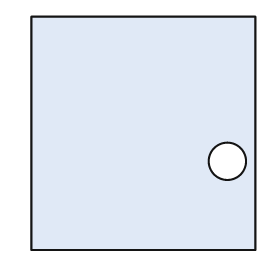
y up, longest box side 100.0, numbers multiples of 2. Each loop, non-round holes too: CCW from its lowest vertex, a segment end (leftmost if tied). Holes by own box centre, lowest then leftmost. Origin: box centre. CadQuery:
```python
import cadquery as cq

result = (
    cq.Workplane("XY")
    .moveTo(-48.0, -50.0)
    .lineTo(48.0, -50.0)
    .lineTo(48.0, 50.0)
    .lineTo(-48.0, 50.0)
    .close()
    .moveTo(36.0, -12.0)
    .circle(8.0)
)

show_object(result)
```